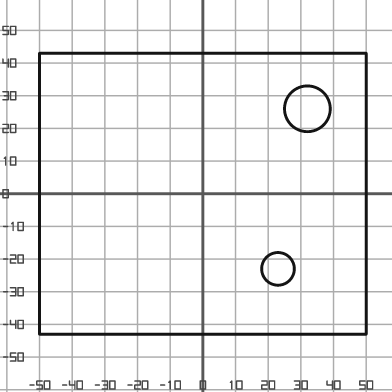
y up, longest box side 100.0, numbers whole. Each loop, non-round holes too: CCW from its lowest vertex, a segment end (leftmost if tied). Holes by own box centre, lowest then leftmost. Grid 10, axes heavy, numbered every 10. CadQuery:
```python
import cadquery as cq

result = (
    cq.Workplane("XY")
    .moveTo(-50.0, -43.0)
    .lineTo(50.0, -43.0)
    .lineTo(50.0, 43.0)
    .lineTo(-50.0, 43.0)
    .close()
    .moveTo(23.0, -23.0)
    .circle(5.0)
    .moveTo(32.0, 26.0)
    .circle(7.0)
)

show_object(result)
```